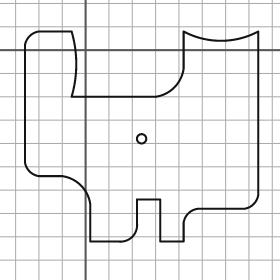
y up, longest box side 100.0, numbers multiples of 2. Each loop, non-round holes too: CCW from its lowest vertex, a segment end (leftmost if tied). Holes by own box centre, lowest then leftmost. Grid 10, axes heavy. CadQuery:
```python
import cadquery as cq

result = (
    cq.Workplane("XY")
    .moveTo(2.0, -82.0)
    .lineTo(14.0, -82.0)
    .threePointArc((20.0, -80.0), (22.0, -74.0))
    .lineTo(22.0, -64.0)
    .lineTo(32.0, -64.0)
    .lineTo(32.0, -82.0)
    .lineTo(42.0, -82.0)
    .lineTo(42.0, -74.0)
    .threePointArc((44.0, -70.0), (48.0, -68.0))
    .lineTo(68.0, -68.0)
    .threePointArc((72.0, -66.0), (74.0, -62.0))
    .lineTo(74.0, 8.0)
    .threePointArc((58.0, 4.0), (42.0, 8.0))
    .lineTo(42.0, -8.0)
    .threePointArc((38.0, -16.0), (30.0, -20.0))
    .lineTo(-6.0, -20.0)
    .threePointArc((-4.0, -6.0), (-6.0, 8.0))
    .lineTo(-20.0, 8.0)
    .threePointArc((-24.0, 6.0), (-26.0, 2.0))
    .lineTo(-26.0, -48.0)
    .threePointArc((-24.0, -52.0), (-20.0, -54.0))
    .lineTo(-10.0, -54.0)
    .threePointArc((-2.0, -58.0), (2.0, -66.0))
    .close()
    .moveTo(24.0, -38.0)
    .circle(2.0)
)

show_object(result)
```